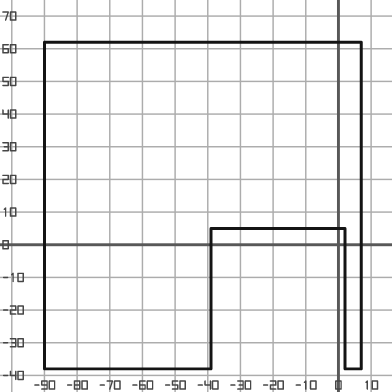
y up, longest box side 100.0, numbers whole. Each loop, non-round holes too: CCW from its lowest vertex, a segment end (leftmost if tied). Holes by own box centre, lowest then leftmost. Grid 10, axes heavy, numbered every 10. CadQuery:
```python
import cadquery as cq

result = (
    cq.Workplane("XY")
    .moveTo(-90.0, -38.0)
    .lineTo(-39.0, -38.0)
    .lineTo(-39.0, 5.0)
    .lineTo(2.0, 5.0)
    .lineTo(2.0, -38.0)
    .lineTo(7.0, -38.0)
    .lineTo(7.0, 62.0)
    .lineTo(-90.0, 62.0)
    .close()
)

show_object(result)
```